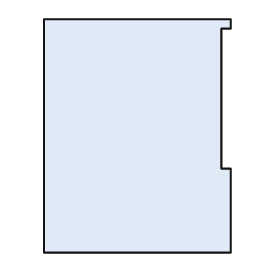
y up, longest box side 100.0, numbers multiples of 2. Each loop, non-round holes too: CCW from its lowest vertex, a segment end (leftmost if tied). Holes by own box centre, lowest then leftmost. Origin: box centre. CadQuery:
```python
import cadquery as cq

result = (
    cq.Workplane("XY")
    .moveTo(-40.0, -50.0)
    .lineTo(40.0, -50.0)
    .lineTo(40.0, -14.0)
    .lineTo(36.0, -14.0)
    .lineTo(36.0, 46.0)
    .lineTo(40.0, 46.0)
    .lineTo(40.0, 50.0)
    .lineTo(-40.0, 50.0)
    .close()
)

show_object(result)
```